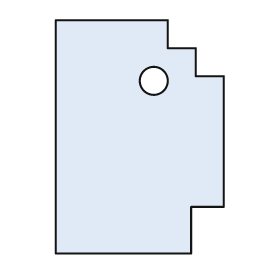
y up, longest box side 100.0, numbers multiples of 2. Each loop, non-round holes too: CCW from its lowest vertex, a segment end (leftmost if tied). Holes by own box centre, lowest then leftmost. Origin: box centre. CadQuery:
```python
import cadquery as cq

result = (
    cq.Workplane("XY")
    .moveTo(-36.0, -50.0)
    .lineTo(22.0, -50.0)
    .lineTo(22.0, -30.0)
    .lineTo(36.0, -30.0)
    .lineTo(36.0, 26.0)
    .lineTo(24.0, 26.0)
    .lineTo(24.0, 38.0)
    .lineTo(12.0, 38.0)
    .lineTo(12.0, 50.0)
    .lineTo(-36.0, 50.0)
    .close()
    .moveTo(6.0, 24.0)
    .circle(6.0)
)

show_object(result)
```